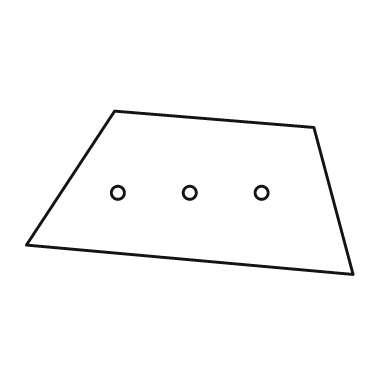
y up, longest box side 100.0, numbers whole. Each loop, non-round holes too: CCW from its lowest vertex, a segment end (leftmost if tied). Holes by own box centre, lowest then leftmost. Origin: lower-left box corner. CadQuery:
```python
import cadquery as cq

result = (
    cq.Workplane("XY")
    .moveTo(100.0, 0.0)
    .lineTo(88.0, 45.0)
    .lineTo(27.0, 50.0)
    .lineTo(0.0, 9.0)
    .close()
    .moveTo(28.0, 25.0)
    .circle(2.0)
    .moveTo(50.0, 25.0)
    .circle(2.0)
    .moveTo(72.0, 25.0)
    .circle(2.0)
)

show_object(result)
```